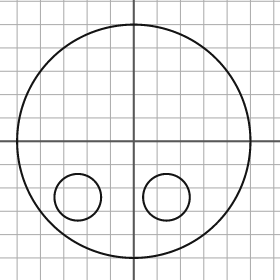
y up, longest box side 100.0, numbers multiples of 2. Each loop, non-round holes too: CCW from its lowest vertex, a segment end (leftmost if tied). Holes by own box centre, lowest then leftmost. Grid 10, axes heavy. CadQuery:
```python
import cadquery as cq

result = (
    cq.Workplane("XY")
    .moveTo(0.0, 0.0)
    .circle(50.0)
    .moveTo(-24.0, -24.0)
    .circle(10.0)
    .moveTo(14.0, -24.0)
    .circle(10.0)
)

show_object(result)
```